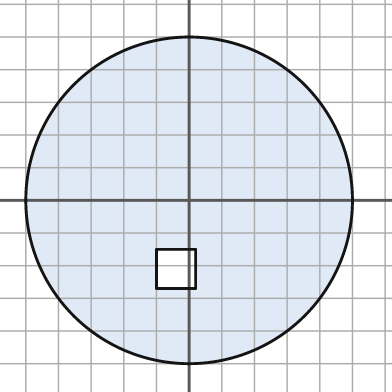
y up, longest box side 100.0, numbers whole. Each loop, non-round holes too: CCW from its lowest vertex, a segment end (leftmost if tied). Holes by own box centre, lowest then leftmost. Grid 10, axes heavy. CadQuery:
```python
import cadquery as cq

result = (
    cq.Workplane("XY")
    .moveTo(0.0, 0.0)
    .circle(50.0)
    .moveTo(-10.0, -27.0)
    .lineTo(2.0, -27.0)
    .lineTo(2.0, -15.0)
    .lineTo(-10.0, -15.0)
    .close()
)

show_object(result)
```